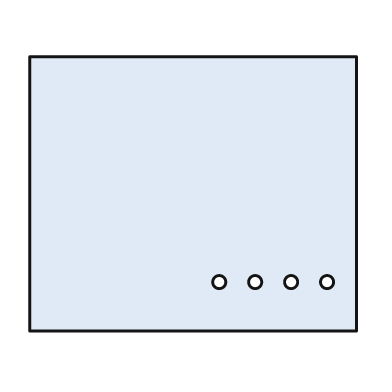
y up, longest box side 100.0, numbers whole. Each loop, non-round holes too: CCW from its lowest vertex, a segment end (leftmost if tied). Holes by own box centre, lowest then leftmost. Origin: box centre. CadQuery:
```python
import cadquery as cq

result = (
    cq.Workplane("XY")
    .moveTo(-50.0, -42.0)
    .lineTo(50.0, -42.0)
    .lineTo(50.0, 42.0)
    .lineTo(-50.0, 42.0)
    .close()
    .moveTo(8.0, -27.0)
    .circle(2.0)
    .moveTo(19.0, -27.0)
    .circle(2.0)
    .moveTo(30.0, -27.0)
    .circle(2.0)
    .moveTo(41.0, -27.0)
    .circle(2.0)
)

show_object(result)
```